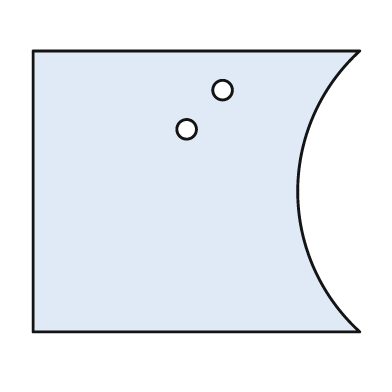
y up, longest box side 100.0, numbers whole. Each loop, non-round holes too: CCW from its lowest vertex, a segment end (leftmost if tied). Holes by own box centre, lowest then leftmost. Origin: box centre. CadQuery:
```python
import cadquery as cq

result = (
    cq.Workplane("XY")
    .moveTo(-50.0, -43.0)
    .lineTo(50.0, -43.0)
    .threePointArc((31.0, 0.0), (50.0, 43.0))
    .lineTo(-50.0, 43.0)
    .close()
    .moveTo(-3.0, 19.0)
    .circle(3.0)
    .moveTo(8.0, 31.0)
    .circle(3.0)
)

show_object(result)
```